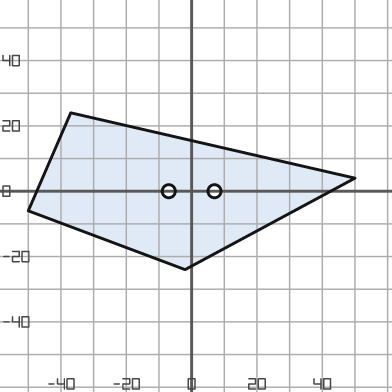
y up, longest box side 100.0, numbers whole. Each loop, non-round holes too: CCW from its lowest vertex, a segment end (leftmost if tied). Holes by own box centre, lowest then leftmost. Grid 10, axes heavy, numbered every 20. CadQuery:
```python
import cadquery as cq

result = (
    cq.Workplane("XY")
    .moveTo(-2.0, -24.0)
    .lineTo(50.0, 4.0)
    .lineTo(-37.0, 24.0)
    .lineTo(-50.0, -6.0)
    .close()
    .moveTo(-7.0, 0.0)
    .circle(2.0)
    .moveTo(7.0, 0.0)
    .circle(2.0)
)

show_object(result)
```